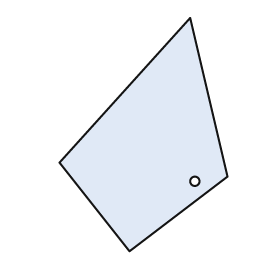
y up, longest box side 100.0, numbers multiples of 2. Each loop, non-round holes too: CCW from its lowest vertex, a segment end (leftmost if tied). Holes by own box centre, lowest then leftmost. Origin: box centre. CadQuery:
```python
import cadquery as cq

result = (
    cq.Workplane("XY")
    .moveTo(-6.0, -50.0)
    .lineTo(36.0, -18.0)
    .lineTo(20.0, 50.0)
    .lineTo(-36.0, -12.0)
    .close()
    .moveTo(22.0, -20.0)
    .circle(2.0)
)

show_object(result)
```